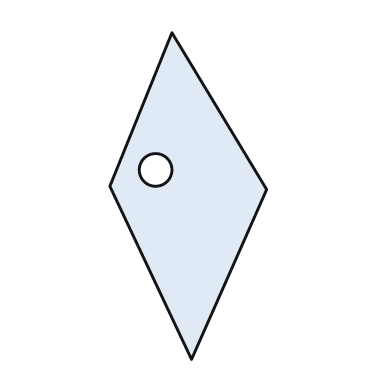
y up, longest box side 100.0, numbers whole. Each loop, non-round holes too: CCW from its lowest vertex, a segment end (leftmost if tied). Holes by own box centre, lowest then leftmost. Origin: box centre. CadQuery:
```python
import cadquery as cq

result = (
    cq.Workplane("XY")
    .moveTo(1.0, -50.0)
    .lineTo(24.0, 2.0)
    .lineTo(-5.0, 50.0)
    .lineTo(-24.0, 3.0)
    .close()
    .moveTo(-10.0, 8.0)
    .circle(5.0)
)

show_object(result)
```